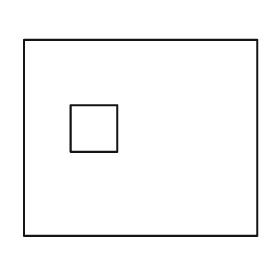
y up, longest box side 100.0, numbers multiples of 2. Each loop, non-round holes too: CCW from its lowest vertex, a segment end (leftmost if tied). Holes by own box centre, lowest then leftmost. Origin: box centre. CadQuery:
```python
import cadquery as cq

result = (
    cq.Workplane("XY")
    .moveTo(-50.0, -42.0)
    .lineTo(50.0, -42.0)
    .lineTo(50.0, 42.0)
    .lineTo(-50.0, 42.0)
    .close()
    .moveTo(-30.0, -6.0)
    .lineTo(-10.0, -6.0)
    .lineTo(-10.0, 14.0)
    .lineTo(-30.0, 14.0)
    .close()
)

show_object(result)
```